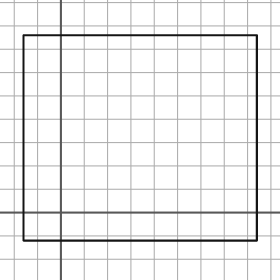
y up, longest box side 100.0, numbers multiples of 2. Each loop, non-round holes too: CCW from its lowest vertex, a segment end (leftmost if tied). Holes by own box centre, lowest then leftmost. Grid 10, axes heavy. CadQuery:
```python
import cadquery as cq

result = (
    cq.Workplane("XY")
    .moveTo(-16.0, -12.0)
    .lineTo(84.0, -12.0)
    .lineTo(84.0, 76.0)
    .lineTo(-16.0, 76.0)
    .close()
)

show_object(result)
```